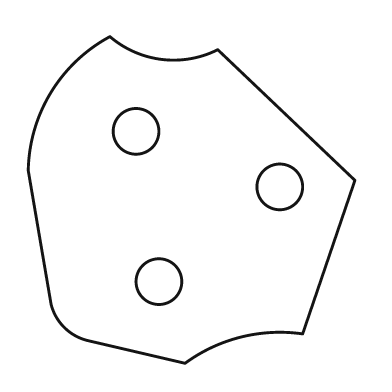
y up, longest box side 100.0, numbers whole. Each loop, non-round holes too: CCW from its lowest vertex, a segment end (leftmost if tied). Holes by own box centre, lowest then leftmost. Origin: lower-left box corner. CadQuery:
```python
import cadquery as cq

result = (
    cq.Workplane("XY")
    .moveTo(48.0, 0.0)
    .threePointArc((65.0, 8.0), (84.0, 9.0))
    .lineTo(100.0, 56.0)
    .lineTo(58.0, 96.0)
    .threePointArc((41.0, 93.0), (25.0, 100.0))
    .threePointArc((7.0, 83.0), (0.0, 59.0))
    .lineTo(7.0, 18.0)
    .threePointArc((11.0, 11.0), (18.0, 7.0))
    .close()
    .moveTo(40.0, 25.0)
    .circle(7.0)
    .moveTo(77.0, 54.0)
    .circle(7.0)
    .moveTo(33.0, 71.0)
    .circle(7.0)
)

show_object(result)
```